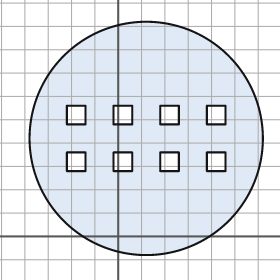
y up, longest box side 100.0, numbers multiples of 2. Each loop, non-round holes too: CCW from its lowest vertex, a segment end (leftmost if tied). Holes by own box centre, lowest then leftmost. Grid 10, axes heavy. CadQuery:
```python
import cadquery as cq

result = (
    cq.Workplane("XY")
    .moveTo(12.0, 42.0)
    .circle(50.0)
    .moveTo(-22.0, 28.0)
    .lineTo(-14.0, 28.0)
    .lineTo(-14.0, 36.0)
    .lineTo(-22.0, 36.0)
    .close()
    .moveTo(-2.0, 28.0)
    .lineTo(6.0, 28.0)
    .lineTo(6.0, 36.0)
    .lineTo(-2.0, 36.0)
    .close()
    .moveTo(18.0, 28.0)
    .lineTo(26.0, 28.0)
    .lineTo(26.0, 36.0)
    .lineTo(18.0, 36.0)
    .close()
    .moveTo(38.0, 28.0)
    .lineTo(46.0, 28.0)
    .lineTo(46.0, 36.0)
    .lineTo(38.0, 36.0)
    .close()
    .moveTo(-22.0, 48.0)
    .lineTo(-14.0, 48.0)
    .lineTo(-14.0, 56.0)
    .lineTo(-22.0, 56.0)
    .close()
    .moveTo(-2.0, 48.0)
    .lineTo(6.0, 48.0)
    .lineTo(6.0, 56.0)
    .lineTo(-2.0, 56.0)
    .close()
    .moveTo(18.0, 48.0)
    .lineTo(26.0, 48.0)
    .lineTo(26.0, 56.0)
    .lineTo(18.0, 56.0)
    .close()
    .moveTo(38.0, 48.0)
    .lineTo(46.0, 48.0)
    .lineTo(46.0, 56.0)
    .lineTo(38.0, 56.0)
    .close()
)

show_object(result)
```